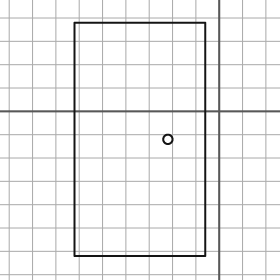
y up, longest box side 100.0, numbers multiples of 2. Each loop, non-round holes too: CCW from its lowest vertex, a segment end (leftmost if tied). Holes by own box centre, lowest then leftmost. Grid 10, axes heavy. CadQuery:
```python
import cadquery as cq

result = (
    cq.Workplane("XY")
    .moveTo(-62.0, -62.0)
    .lineTo(-6.0, -62.0)
    .lineTo(-6.0, 38.0)
    .lineTo(-62.0, 38.0)
    .close()
    .moveTo(-22.0, -12.0)
    .circle(2.0)
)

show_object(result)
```